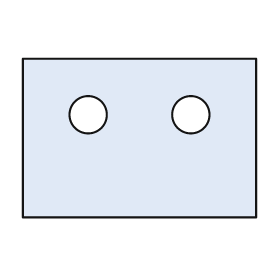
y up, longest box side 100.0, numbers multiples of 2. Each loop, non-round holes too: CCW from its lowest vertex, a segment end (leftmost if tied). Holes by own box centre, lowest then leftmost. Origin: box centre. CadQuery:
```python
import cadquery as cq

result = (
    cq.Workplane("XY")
    .moveTo(-50.0, -34.0)
    .lineTo(50.0, -34.0)
    .lineTo(50.0, 34.0)
    .lineTo(-50.0, 34.0)
    .close()
    .moveTo(-22.0, 10.0)
    .circle(8.0)
    .moveTo(22.0, 10.0)
    .circle(8.0)
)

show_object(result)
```